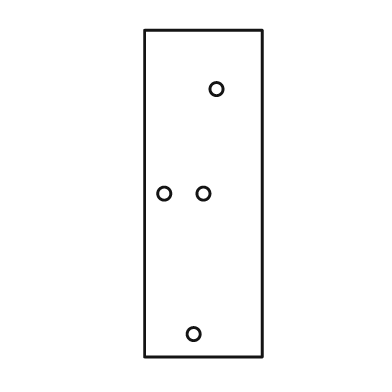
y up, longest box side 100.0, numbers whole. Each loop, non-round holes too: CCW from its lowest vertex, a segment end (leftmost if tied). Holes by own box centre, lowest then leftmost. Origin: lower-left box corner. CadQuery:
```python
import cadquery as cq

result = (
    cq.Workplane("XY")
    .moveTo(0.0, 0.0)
    .lineTo(36.0, 0.0)
    .lineTo(36.0, 100.0)
    .lineTo(0.0, 100.0)
    .close()
    .moveTo(15.0, 7.0)
    .circle(2.0)
    .moveTo(6.0, 50.0)
    .circle(2.0)
    .moveTo(18.0, 50.0)
    .circle(2.0)
    .moveTo(22.0, 82.0)
    .circle(2.0)
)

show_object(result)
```